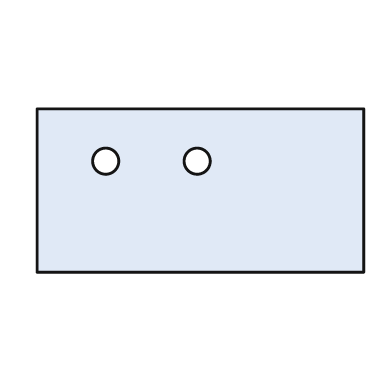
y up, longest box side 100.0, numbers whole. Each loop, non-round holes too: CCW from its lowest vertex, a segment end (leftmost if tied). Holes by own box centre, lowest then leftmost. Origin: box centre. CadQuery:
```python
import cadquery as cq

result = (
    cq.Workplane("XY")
    .moveTo(-50.0, -25.0)
    .lineTo(50.0, -25.0)
    .lineTo(50.0, 25.0)
    .lineTo(-50.0, 25.0)
    .close()
    .moveTo(-29.0, 9.0)
    .circle(4.0)
    .moveTo(-1.0, 9.0)
    .circle(4.0)
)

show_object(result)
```